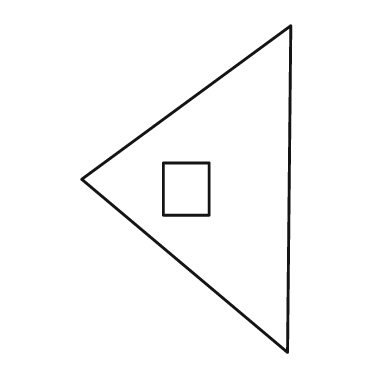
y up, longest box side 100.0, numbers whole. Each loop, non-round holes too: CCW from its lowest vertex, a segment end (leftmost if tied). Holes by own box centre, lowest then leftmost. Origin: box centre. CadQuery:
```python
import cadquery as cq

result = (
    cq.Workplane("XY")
    .moveTo(31.0, -50.0)
    .lineTo(32.0, 50.0)
    .lineTo(-32.0, 3.0)
    .close()
    .moveTo(-7.0, -8.0)
    .lineTo(7.0, -8.0)
    .lineTo(7.0, 8.0)
    .lineTo(-7.0, 8.0)
    .close()
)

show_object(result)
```